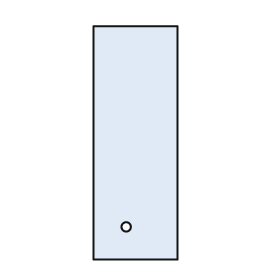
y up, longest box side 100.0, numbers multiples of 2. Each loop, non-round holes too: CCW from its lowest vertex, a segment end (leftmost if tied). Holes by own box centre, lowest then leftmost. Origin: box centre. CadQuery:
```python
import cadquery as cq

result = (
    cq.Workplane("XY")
    .moveTo(-18.0, -50.0)
    .lineTo(18.0, -50.0)
    .lineTo(18.0, 50.0)
    .lineTo(-18.0, 50.0)
    .close()
    .moveTo(-4.0, -36.0)
    .circle(2.0)
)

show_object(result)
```